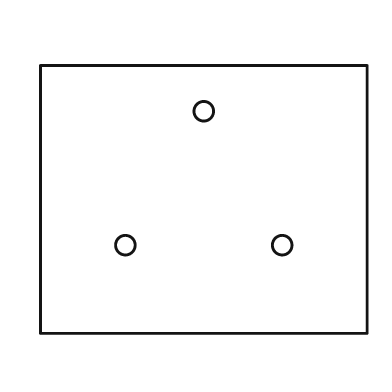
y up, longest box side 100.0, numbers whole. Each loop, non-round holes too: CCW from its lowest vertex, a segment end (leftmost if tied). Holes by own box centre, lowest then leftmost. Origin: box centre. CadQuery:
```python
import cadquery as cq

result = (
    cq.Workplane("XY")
    .moveTo(-50.0, -41.0)
    .lineTo(50.0, -41.0)
    .lineTo(50.0, 41.0)
    .lineTo(-50.0, 41.0)
    .close()
    .moveTo(-24.0, -14.0)
    .circle(3.0)
    .moveTo(24.0, -14.0)
    .circle(3.0)
    .moveTo(0.0, 27.0)
    .circle(3.0)
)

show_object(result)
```